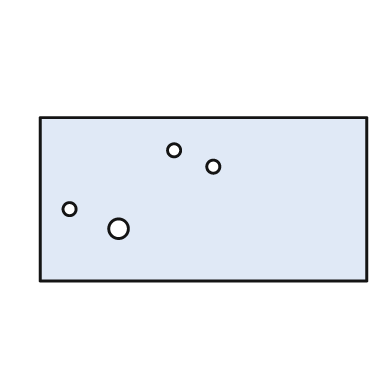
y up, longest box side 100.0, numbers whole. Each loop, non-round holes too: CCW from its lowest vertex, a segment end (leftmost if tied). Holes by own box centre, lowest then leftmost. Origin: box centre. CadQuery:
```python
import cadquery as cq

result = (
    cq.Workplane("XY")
    .moveTo(-50.0, -25.0)
    .lineTo(50.0, -25.0)
    .lineTo(50.0, 25.0)
    .lineTo(-50.0, 25.0)
    .close()
    .moveTo(-26.0, -9.0)
    .circle(3.0)
    .moveTo(-41.0, -3.0)
    .circle(2.0)
    .moveTo(3.0, 10.0)
    .circle(2.0)
    .moveTo(-9.0, 15.0)
    .circle(2.0)
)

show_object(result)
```